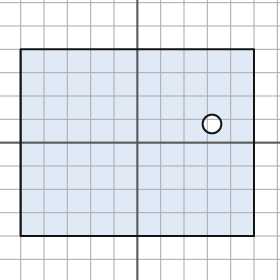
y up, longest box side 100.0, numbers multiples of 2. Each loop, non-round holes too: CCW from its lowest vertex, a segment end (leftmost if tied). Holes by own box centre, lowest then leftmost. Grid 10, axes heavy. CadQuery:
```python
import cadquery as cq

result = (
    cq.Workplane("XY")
    .moveTo(-50.0, -40.0)
    .lineTo(50.0, -40.0)
    .lineTo(50.0, 40.0)
    .lineTo(-50.0, 40.0)
    .close()
    .moveTo(32.0, 8.0)
    .circle(4.0)
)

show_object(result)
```